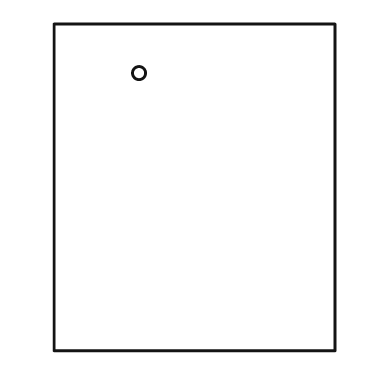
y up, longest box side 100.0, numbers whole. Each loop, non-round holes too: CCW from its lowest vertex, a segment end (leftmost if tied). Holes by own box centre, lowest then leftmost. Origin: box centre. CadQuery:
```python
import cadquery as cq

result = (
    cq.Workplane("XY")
    .moveTo(-43.0, -50.0)
    .lineTo(43.0, -50.0)
    .lineTo(43.0, 50.0)
    .lineTo(-43.0, 50.0)
    .close()
    .moveTo(-17.0, 35.0)
    .circle(2.0)
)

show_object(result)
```